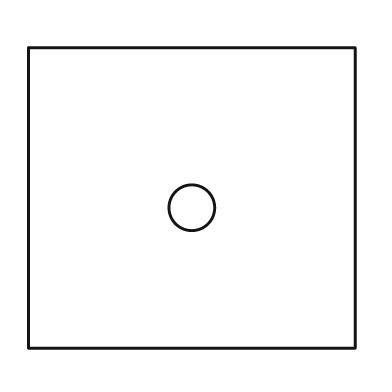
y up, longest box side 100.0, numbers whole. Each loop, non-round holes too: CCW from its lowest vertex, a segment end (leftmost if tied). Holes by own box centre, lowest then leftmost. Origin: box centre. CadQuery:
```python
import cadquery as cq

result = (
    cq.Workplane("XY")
    .moveTo(-50.0, -46.0)
    .lineTo(50.0, -46.0)
    .lineTo(50.0, 46.0)
    .lineTo(-50.0, 46.0)
    .close()
    .moveTo(0.0, -3.0)
    .circle(7.0)
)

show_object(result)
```